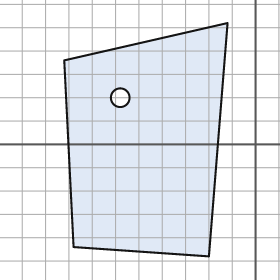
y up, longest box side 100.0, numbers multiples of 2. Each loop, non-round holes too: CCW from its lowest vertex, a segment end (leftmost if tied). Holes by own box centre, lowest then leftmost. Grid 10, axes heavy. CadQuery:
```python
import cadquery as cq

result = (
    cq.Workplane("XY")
    .moveTo(-20.0, -48.0)
    .lineTo(-12.0, 52.0)
    .lineTo(-82.0, 36.0)
    .lineTo(-78.0, -44.0)
    .close()
    .moveTo(-58.0, 20.0)
    .circle(4.0)
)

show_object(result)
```